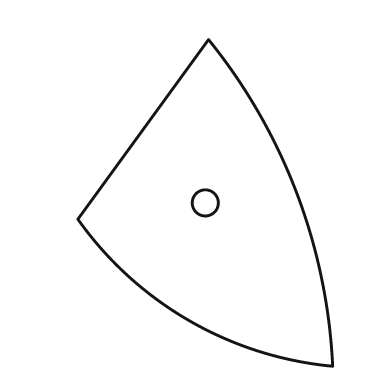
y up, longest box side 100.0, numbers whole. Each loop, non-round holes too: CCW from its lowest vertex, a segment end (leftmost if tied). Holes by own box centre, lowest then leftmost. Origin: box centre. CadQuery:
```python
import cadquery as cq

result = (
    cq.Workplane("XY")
    .moveTo(39.0, -50.0)
    .threePointArc((28.0, 3.0), (1.0, 50.0))
    .lineTo(-39.0, -5.0)
    .threePointArc((-5.0, -36.0), (39.0, -50.0))
    .close()
    .moveTo(0.0, 0.0)
    .circle(4.0)
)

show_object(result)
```